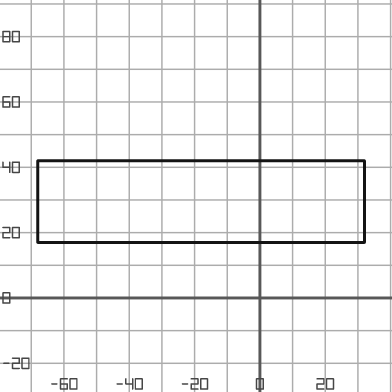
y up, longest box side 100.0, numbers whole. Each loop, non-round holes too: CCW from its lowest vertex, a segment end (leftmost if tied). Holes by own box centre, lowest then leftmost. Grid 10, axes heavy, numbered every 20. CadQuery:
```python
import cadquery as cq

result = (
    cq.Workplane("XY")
    .moveTo(-68.0, 17.0)
    .lineTo(32.0, 17.0)
    .lineTo(32.0, 42.0)
    .lineTo(-68.0, 42.0)
    .close()
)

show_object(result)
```